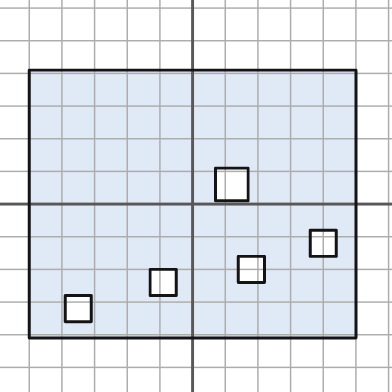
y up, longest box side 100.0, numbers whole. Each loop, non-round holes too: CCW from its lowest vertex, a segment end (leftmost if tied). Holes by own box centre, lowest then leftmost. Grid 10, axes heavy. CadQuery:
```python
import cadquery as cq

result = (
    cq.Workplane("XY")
    .moveTo(-50.0, -41.0)
    .lineTo(50.0, -41.0)
    .lineTo(50.0, 41.0)
    .lineTo(-50.0, 41.0)
    .close()
    .moveTo(-39.0, -36.0)
    .lineTo(-31.0, -36.0)
    .lineTo(-31.0, -28.0)
    .lineTo(-39.0, -28.0)
    .close()
    .moveTo(-13.0, -28.0)
    .lineTo(-5.0, -28.0)
    .lineTo(-5.0, -20.0)
    .lineTo(-13.0, -20.0)
    .close()
    .moveTo(14.0, -24.0)
    .lineTo(22.0, -24.0)
    .lineTo(22.0, -16.0)
    .lineTo(14.0, -16.0)
    .close()
    .moveTo(36.0, -16.0)
    .lineTo(44.0, -16.0)
    .lineTo(44.0, -8.0)
    .lineTo(36.0, -8.0)
    .close()
    .moveTo(7.0, 1.0)
    .lineTo(17.0, 1.0)
    .lineTo(17.0, 11.0)
    .lineTo(7.0, 11.0)
    .close()
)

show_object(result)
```